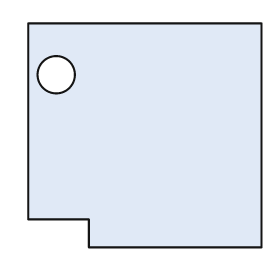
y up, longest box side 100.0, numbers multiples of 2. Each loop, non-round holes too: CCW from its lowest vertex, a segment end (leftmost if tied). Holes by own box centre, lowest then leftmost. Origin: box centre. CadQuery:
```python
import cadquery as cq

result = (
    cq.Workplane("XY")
    .moveTo(-24.0, -48.0)
    .lineTo(50.0, -48.0)
    .lineTo(50.0, 48.0)
    .lineTo(-50.0, 48.0)
    .lineTo(-50.0, -36.0)
    .lineTo(-24.0, -36.0)
    .close()
    .moveTo(-38.0, 26.0)
    .circle(8.0)
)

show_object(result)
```